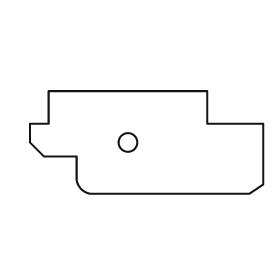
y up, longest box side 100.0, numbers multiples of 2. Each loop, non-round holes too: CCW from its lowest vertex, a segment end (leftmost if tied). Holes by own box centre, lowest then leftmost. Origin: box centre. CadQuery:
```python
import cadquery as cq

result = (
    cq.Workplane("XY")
    .moveTo(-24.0, -22.0)
    .lineTo(44.0, -22.0)
    .lineTo(50.0, -18.0)
    .lineTo(50.0, 8.0)
    .lineTo(26.0, 8.0)
    .lineTo(26.0, 22.0)
    .lineTo(-42.0, 22.0)
    .lineTo(-42.0, 8.0)
    .lineTo(-50.0, 8.0)
    .lineTo(-50.0, 0.0)
    .lineTo(-44.0, -6.0)
    .lineTo(-30.0, -6.0)
    .lineTo(-30.0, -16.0)
    .threePointArc((-28.0, -20.0), (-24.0, -22.0))
    .close()
    .moveTo(-8.0, 0.0)
    .circle(4.0)
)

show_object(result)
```